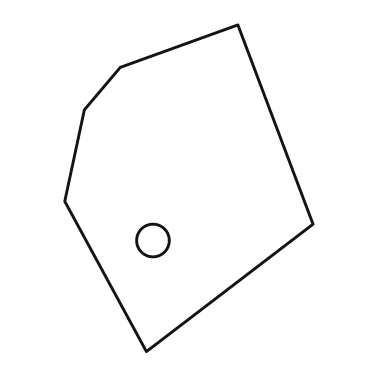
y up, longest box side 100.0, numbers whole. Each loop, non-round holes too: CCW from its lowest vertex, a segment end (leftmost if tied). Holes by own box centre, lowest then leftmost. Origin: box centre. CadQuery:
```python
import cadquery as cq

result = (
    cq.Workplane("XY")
    .moveTo(-13.0, -50.0)
    .lineTo(38.0, -11.0)
    .lineTo(15.0, 50.0)
    .lineTo(-21.0, 37.0)
    .lineTo(-32.0, 24.0)
    .lineTo(-38.0, -4.0)
    .close()
    .moveTo(-11.0, -16.0)
    .circle(5.0)
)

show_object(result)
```